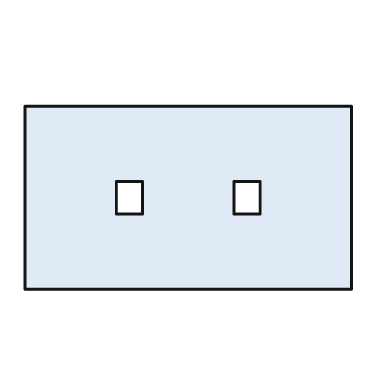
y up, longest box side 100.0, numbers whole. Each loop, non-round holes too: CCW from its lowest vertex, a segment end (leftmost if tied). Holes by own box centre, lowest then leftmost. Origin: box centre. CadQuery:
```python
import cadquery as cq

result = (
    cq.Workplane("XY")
    .moveTo(-50.0, -28.0)
    .lineTo(50.0, -28.0)
    .lineTo(50.0, 28.0)
    .lineTo(-50.0, 28.0)
    .close()
    .moveTo(-22.0, -5.0)
    .lineTo(-14.0, -5.0)
    .lineTo(-14.0, 5.0)
    .lineTo(-22.0, 5.0)
    .close()
    .moveTo(14.0, -5.0)
    .lineTo(22.0, -5.0)
    .lineTo(22.0, 5.0)
    .lineTo(14.0, 5.0)
    .close()
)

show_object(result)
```